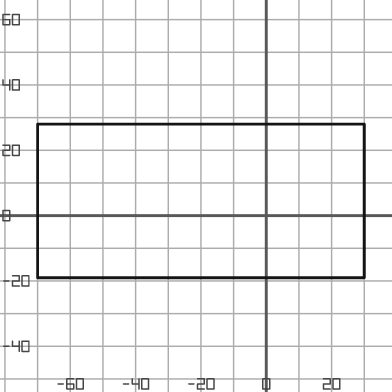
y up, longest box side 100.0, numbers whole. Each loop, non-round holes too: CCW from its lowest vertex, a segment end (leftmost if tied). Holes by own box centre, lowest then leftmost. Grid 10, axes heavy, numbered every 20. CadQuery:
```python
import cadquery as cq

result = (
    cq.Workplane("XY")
    .moveTo(-70.0, -19.0)
    .lineTo(30.0, -19.0)
    .lineTo(30.0, 28.0)
    .lineTo(-70.0, 28.0)
    .close()
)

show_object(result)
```